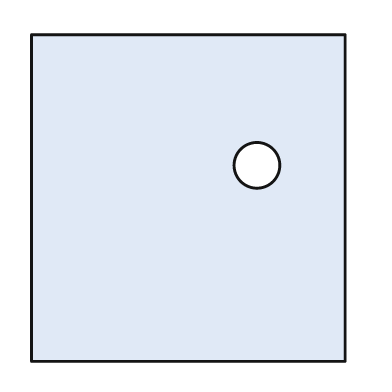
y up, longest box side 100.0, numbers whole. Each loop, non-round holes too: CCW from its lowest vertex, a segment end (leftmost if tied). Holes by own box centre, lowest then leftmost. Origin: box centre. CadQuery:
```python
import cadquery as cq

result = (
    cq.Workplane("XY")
    .moveTo(-48.0, -50.0)
    .lineTo(48.0, -50.0)
    .lineTo(48.0, 50.0)
    .lineTo(-48.0, 50.0)
    .close()
    .moveTo(21.0, 10.0)
    .circle(7.0)
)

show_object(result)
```